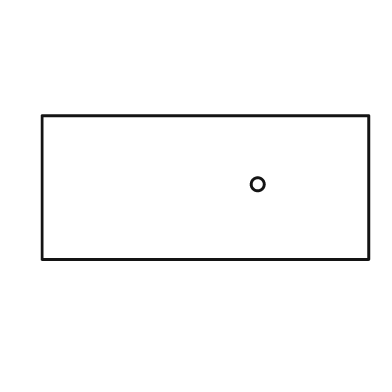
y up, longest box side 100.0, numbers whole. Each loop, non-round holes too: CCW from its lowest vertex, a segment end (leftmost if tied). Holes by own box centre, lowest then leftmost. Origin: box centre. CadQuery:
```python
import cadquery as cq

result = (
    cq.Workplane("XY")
    .moveTo(-50.0, -22.0)
    .lineTo(50.0, -22.0)
    .lineTo(50.0, 22.0)
    .lineTo(-50.0, 22.0)
    .close()
    .moveTo(16.0, 1.0)
    .circle(2.0)
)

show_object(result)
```